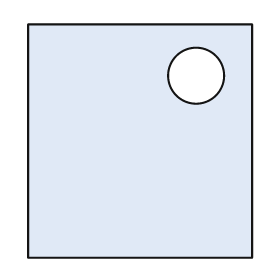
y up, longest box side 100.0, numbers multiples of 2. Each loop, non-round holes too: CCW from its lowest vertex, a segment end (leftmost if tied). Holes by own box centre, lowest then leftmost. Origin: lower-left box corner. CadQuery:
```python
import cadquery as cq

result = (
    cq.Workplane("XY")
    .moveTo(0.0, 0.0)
    .lineTo(96.0, 0.0)
    .lineTo(96.0, 100.0)
    .lineTo(0.0, 100.0)
    .close()
    .moveTo(72.0, 78.0)
    .circle(12.0)
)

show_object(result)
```